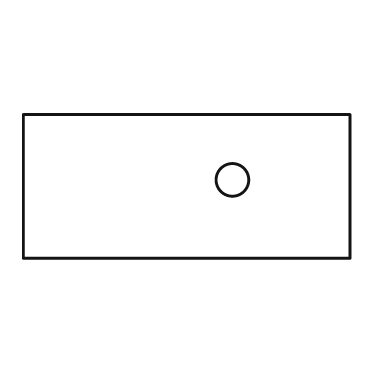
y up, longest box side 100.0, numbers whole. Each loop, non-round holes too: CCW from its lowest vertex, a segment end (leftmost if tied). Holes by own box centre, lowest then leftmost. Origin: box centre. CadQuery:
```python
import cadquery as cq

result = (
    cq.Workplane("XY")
    .moveTo(-50.0, -22.0)
    .lineTo(50.0, -22.0)
    .lineTo(50.0, 22.0)
    .lineTo(-50.0, 22.0)
    .close()
    .moveTo(14.0, 2.0)
    .circle(5.0)
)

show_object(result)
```